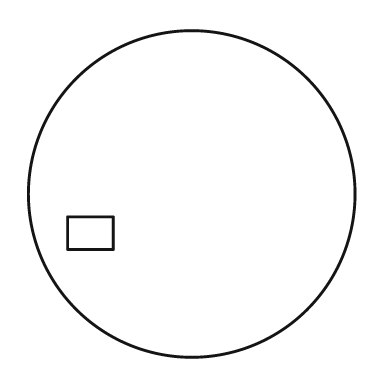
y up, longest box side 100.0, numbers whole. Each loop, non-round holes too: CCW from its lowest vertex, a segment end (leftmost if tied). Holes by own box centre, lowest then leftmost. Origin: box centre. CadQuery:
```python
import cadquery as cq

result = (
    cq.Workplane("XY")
    .moveTo(0.0, 0.0)
    .circle(50.0)
    .moveTo(-38.0, -17.0)
    .lineTo(-24.0, -17.0)
    .lineTo(-24.0, -7.0)
    .lineTo(-38.0, -7.0)
    .close()
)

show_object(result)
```